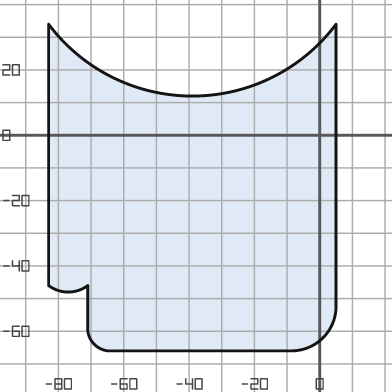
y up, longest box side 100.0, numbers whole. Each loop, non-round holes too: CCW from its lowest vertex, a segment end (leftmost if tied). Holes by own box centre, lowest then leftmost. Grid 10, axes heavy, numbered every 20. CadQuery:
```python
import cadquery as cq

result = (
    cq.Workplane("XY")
    .moveTo(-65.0, -66.0)
    .lineTo(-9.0, -66.0)
    .threePointArc((1.0, -62.0), (5.0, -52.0))
    .lineTo(5.0, 34.0)
    .threePointArc((-39.0, 12.0), (-83.0, 34.0))
    .lineTo(-83.0, -46.0)
    .threePointArc((-77.0, -48.0), (-71.0, -46.0))
    .lineTo(-71.0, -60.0)
    .threePointArc((-69.0, -64.0), (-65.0, -66.0))
    .close()
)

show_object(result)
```